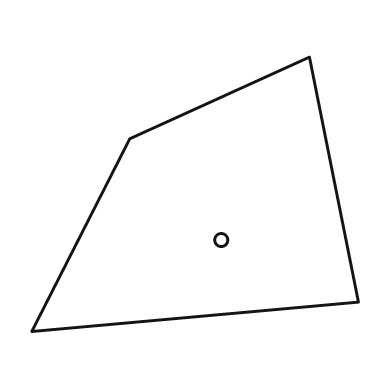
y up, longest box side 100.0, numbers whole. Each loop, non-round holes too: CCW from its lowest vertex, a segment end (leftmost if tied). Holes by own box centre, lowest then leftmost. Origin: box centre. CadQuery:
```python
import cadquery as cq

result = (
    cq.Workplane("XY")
    .moveTo(-50.0, -42.0)
    .lineTo(50.0, -33.0)
    .lineTo(35.0, 42.0)
    .lineTo(-20.0, 17.0)
    .close()
    .moveTo(8.0, -14.0)
    .circle(2.0)
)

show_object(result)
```